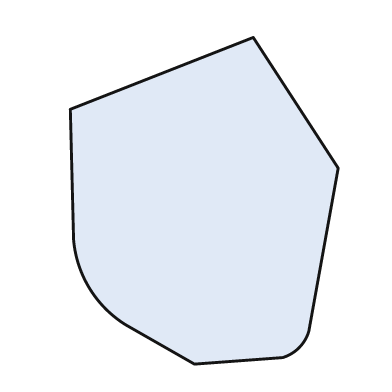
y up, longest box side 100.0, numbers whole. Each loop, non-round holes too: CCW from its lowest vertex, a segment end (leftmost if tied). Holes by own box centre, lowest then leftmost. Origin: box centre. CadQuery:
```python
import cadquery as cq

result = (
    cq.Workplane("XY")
    .moveTo(-3.0, -50.0)
    .lineTo(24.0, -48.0)
    .threePointArc((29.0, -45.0), (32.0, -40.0))
    .lineTo(41.0, 10.0)
    .lineTo(15.0, 50.0)
    .lineTo(-41.0, 28.0)
    .lineTo(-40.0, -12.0)
    .threePointArc((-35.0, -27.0), (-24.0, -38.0))
    .close()
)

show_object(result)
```